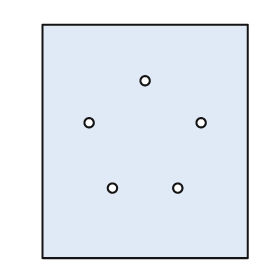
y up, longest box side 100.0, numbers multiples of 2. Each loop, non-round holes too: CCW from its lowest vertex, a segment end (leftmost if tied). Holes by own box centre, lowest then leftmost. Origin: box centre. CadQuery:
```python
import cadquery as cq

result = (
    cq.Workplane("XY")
    .moveTo(-44.0, -50.0)
    .lineTo(44.0, -50.0)
    .lineTo(44.0, 50.0)
    .lineTo(-44.0, 50.0)
    .close()
    .moveTo(-14.0, -20.0)
    .circle(2.0)
    .moveTo(14.0, -20.0)
    .circle(2.0)
    .moveTo(-24.0, 8.0)
    .circle(2.0)
    .moveTo(24.0, 8.0)
    .circle(2.0)
    .moveTo(0.0, 26.0)
    .circle(2.0)
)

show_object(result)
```